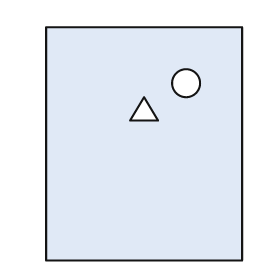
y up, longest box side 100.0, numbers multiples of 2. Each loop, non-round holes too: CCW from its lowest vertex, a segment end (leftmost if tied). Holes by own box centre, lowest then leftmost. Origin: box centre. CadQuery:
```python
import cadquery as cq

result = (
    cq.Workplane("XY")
    .moveTo(-42.0, -50.0)
    .lineTo(42.0, -50.0)
    .lineTo(42.0, 50.0)
    .lineTo(-42.0, 50.0)
    .close()
    .moveTo(-6.0, 10.0)
    .lineTo(6.0, 10.0)
    .lineTo(0.0, 20.0)
    .close()
    .moveTo(18.0, 26.0)
    .circle(6.0)
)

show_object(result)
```